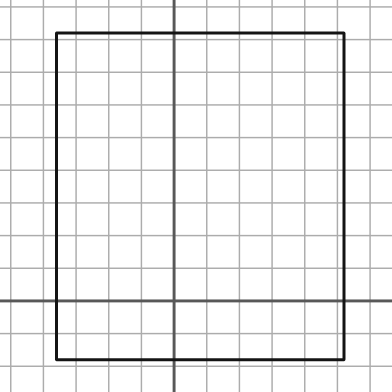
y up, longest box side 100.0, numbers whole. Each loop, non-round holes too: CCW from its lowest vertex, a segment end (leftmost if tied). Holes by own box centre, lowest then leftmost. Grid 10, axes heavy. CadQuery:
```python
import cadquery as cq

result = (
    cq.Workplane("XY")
    .moveTo(-36.0, -18.0)
    .lineTo(52.0, -18.0)
    .lineTo(52.0, 82.0)
    .lineTo(-36.0, 82.0)
    .close()
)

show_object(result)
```